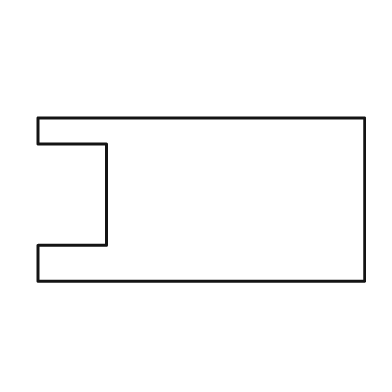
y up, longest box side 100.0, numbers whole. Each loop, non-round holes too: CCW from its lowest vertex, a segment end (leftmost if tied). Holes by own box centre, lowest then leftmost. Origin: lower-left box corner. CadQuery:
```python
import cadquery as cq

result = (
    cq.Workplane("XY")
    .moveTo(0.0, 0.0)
    .lineTo(100.0, 0.0)
    .lineTo(100.0, 50.0)
    .lineTo(0.0, 50.0)
    .lineTo(0.0, 42.0)
    .lineTo(21.0, 42.0)
    .lineTo(21.0, 11.0)
    .lineTo(0.0, 11.0)
    .close()
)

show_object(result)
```